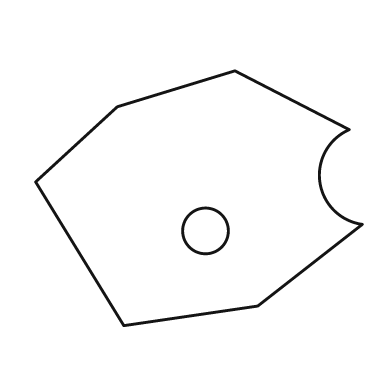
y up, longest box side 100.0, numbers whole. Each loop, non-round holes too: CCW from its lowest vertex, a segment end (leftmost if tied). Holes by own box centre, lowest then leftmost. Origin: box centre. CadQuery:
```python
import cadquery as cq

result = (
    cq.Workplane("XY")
    .moveTo(-23.0, -39.0)
    .lineTo(18.0, -33.0)
    .lineTo(50.0, -8.0)
    .threePointArc((37.0, 5.0), (46.0, 21.0))
    .lineTo(11.0, 39.0)
    .lineTo(-25.0, 28.0)
    .lineTo(-50.0, 5.0)
    .close()
    .moveTo(2.0, -10.0)
    .circle(7.0)
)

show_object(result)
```